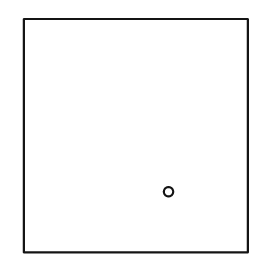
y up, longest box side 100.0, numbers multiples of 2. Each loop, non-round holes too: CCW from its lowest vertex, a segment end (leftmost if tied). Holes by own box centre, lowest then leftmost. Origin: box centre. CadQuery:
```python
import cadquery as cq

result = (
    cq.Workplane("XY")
    .moveTo(-48.0, -50.0)
    .lineTo(48.0, -50.0)
    .lineTo(48.0, 50.0)
    .lineTo(-48.0, 50.0)
    .close()
    .moveTo(14.0, -24.0)
    .circle(2.0)
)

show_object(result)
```